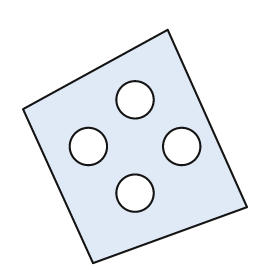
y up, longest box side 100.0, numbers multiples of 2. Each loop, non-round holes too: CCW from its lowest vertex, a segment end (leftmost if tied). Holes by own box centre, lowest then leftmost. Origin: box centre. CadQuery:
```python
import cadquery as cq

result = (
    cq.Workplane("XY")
    .moveTo(-18.0, -50.0)
    .lineTo(48.0, -26.0)
    .lineTo(14.0, 50.0)
    .lineTo(-48.0, 16.0)
    .close()
    .moveTo(0.0, -20.0)
    .circle(8.0)
    .moveTo(-20.0, 0.0)
    .circle(8.0)
    .moveTo(20.0, 0.0)
    .circle(8.0)
    .moveTo(0.0, 20.0)
    .circle(8.0)
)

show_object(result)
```